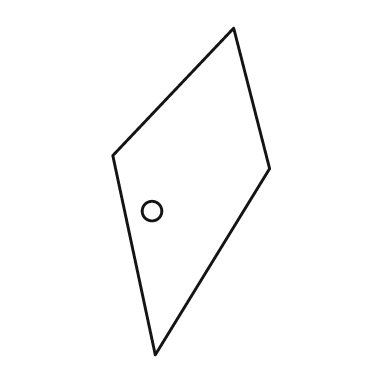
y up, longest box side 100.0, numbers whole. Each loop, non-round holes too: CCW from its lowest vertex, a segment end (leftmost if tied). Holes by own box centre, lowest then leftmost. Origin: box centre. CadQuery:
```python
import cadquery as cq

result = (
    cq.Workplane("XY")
    .moveTo(-11.0, -50.0)
    .lineTo(24.0, 7.0)
    .lineTo(13.0, 50.0)
    .lineTo(-24.0, 11.0)
    .close()
    .moveTo(-12.0, -6.0)
    .circle(3.0)
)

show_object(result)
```